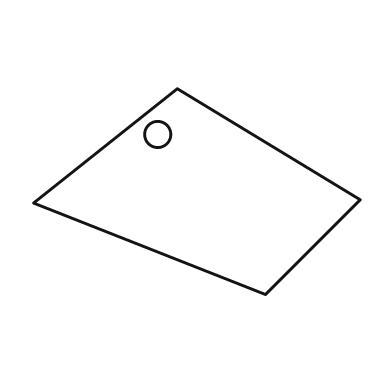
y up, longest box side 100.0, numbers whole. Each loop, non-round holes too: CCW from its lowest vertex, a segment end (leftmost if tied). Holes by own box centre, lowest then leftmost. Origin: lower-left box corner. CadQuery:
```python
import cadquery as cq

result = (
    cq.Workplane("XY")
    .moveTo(71.0, 0.0)
    .lineTo(100.0, 29.0)
    .lineTo(44.0, 63.0)
    .lineTo(0.0, 28.0)
    .close()
    .moveTo(38.0, 49.0)
    .circle(4.0)
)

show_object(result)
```